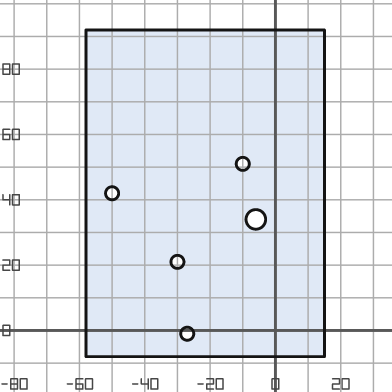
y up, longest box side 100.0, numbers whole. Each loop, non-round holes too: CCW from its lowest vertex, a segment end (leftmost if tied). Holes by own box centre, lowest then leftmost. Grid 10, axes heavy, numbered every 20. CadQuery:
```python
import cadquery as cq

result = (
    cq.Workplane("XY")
    .moveTo(-58.0, -8.0)
    .lineTo(15.0, -8.0)
    .lineTo(15.0, 92.0)
    .lineTo(-58.0, 92.0)
    .close()
    .moveTo(-27.0, -1.0)
    .circle(2.0)
    .moveTo(-30.0, 21.0)
    .circle(2.0)
    .moveTo(-6.0, 34.0)
    .circle(3.0)
    .moveTo(-50.0, 42.0)
    .circle(2.0)
    .moveTo(-10.0, 51.0)
    .circle(2.0)
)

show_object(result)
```